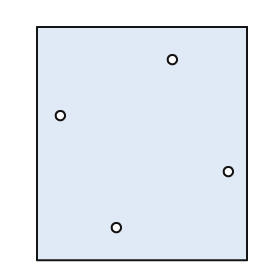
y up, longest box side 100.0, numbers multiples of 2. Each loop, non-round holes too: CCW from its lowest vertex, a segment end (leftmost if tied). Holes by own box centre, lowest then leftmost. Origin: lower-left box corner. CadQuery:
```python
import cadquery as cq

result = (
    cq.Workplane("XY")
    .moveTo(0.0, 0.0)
    .lineTo(90.0, 0.0)
    .lineTo(90.0, 100.0)
    .lineTo(0.0, 100.0)
    .close()
    .moveTo(34.0, 14.0)
    .circle(2.0)
    .moveTo(82.0, 38.0)
    .circle(2.0)
    .moveTo(10.0, 62.0)
    .circle(2.0)
    .moveTo(58.0, 86.0)
    .circle(2.0)
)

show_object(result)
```